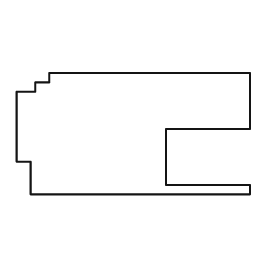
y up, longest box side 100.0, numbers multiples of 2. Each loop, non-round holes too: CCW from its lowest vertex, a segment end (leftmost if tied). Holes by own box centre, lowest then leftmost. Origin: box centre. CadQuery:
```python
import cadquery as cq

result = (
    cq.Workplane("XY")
    .moveTo(-44.0, -26.0)
    .lineTo(50.0, -26.0)
    .lineTo(50.0, -22.0)
    .lineTo(14.0, -22.0)
    .lineTo(14.0, 2.0)
    .lineTo(50.0, 2.0)
    .lineTo(50.0, 26.0)
    .lineTo(-36.0, 26.0)
    .lineTo(-36.0, 22.0)
    .lineTo(-42.0, 22.0)
    .lineTo(-42.0, 18.0)
    .lineTo(-50.0, 18.0)
    .lineTo(-50.0, -12.0)
    .lineTo(-44.0, -12.0)
    .close()
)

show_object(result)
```